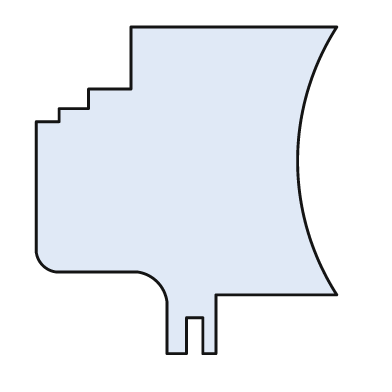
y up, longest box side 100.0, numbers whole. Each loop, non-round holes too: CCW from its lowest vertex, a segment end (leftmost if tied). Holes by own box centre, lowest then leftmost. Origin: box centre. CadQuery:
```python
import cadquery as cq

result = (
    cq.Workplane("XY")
    .moveTo(-6.0, -50.0)
    .lineTo(0.0, -50.0)
    .lineTo(0.0, -39.0)
    .lineTo(5.0, -39.0)
    .lineTo(5.0, -50.0)
    .lineTo(9.0, -50.0)
    .lineTo(9.0, -32.0)
    .lineTo(46.0, -32.0)
    .threePointArc((34.0, 9.0), (46.0, 50.0))
    .lineTo(-17.0, 50.0)
    .lineTo(-17.0, 31.0)
    .lineTo(-30.0, 31.0)
    .lineTo(-30.0, 25.0)
    .lineTo(-39.0, 25.0)
    .lineTo(-39.0, 21.0)
    .lineTo(-46.0, 21.0)
    .lineTo(-46.0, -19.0)
    .threePointArc((-44.0, -23.0), (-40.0, -25.0))
    .lineTo(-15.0, -25.0)
    .threePointArc((-9.0, -28.0), (-6.0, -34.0))
    .close()
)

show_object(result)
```